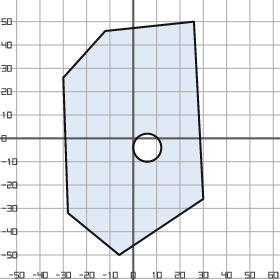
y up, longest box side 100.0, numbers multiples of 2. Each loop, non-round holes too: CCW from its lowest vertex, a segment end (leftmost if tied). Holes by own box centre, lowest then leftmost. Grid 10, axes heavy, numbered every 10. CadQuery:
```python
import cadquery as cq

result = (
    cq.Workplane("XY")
    .moveTo(-6.0, -50.0)
    .lineTo(30.0, -26.0)
    .lineTo(26.0, 50.0)
    .lineTo(-12.0, 46.0)
    .lineTo(-30.0, 26.0)
    .lineTo(-28.0, -32.0)
    .close()
    .moveTo(6.0, -4.0)
    .circle(6.0)
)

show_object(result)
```